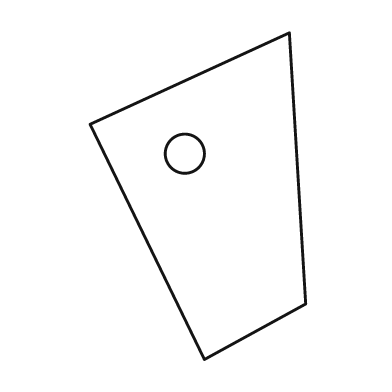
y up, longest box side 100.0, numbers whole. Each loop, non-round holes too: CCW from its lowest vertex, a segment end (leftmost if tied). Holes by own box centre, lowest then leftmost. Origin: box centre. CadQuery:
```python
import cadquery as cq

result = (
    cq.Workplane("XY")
    .moveTo(2.0, -50.0)
    .lineTo(33.0, -33.0)
    .lineTo(28.0, 50.0)
    .lineTo(-33.0, 22.0)
    .close()
    .moveTo(-4.0, 13.0)
    .circle(6.0)
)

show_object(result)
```